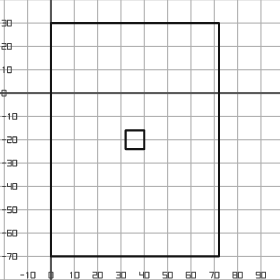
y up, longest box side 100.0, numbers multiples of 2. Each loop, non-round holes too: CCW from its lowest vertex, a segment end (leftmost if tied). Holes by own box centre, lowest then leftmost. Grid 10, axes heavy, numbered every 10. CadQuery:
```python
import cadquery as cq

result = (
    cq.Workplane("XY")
    .moveTo(0.0, -70.0)
    .lineTo(72.0, -70.0)
    .lineTo(72.0, 30.0)
    .lineTo(0.0, 30.0)
    .close()
    .moveTo(32.0, -24.0)
    .lineTo(40.0, -24.0)
    .lineTo(40.0, -16.0)
    .lineTo(32.0, -16.0)
    .close()
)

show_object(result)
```